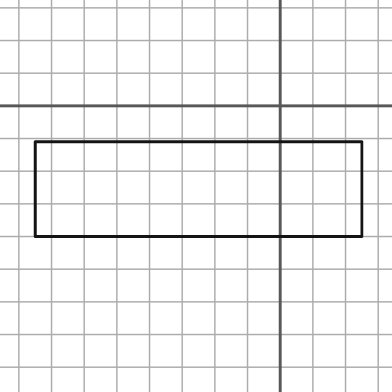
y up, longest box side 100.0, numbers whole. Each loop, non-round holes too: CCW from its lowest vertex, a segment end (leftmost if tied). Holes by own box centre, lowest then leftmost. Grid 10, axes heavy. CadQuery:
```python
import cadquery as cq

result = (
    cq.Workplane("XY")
    .moveTo(-75.0, -40.0)
    .lineTo(25.0, -40.0)
    .lineTo(25.0, -11.0)
    .lineTo(-75.0, -11.0)
    .close()
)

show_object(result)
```